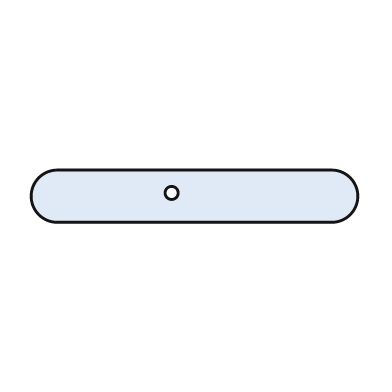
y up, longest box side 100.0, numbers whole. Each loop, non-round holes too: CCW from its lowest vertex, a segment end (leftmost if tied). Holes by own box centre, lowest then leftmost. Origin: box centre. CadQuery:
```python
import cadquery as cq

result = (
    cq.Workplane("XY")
    .moveTo(-42.0, -8.0)
    .lineTo(42.0, -8.0)
    .threePointArc((50.0, 0.0), (42.0, 8.0))
    .lineTo(-42.0, 8.0)
    .threePointArc((-50.0, 0.0), (-42.0, -8.0))
    .close()
    .moveTo(-7.0, 1.0)
    .circle(2.0)
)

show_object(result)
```